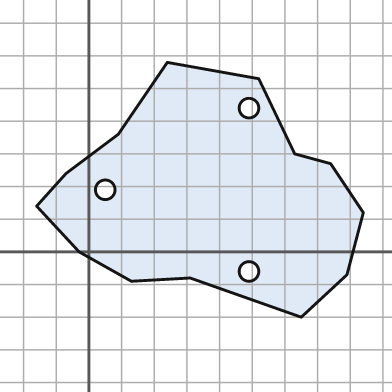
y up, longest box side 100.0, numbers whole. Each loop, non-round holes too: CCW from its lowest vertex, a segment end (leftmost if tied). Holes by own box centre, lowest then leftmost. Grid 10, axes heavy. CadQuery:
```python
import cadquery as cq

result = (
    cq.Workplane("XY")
    .moveTo(65.0, -20.0)
    .lineTo(79.0, -7.0)
    .lineTo(84.0, 12.0)
    .lineTo(74.0, 27.0)
    .lineTo(63.0, 30.0)
    .lineTo(52.0, 53.0)
    .lineTo(24.0, 58.0)
    .lineTo(9.0, 36.0)
    .lineTo(-7.0, 24.0)
    .lineTo(-16.0, 14.0)
    .lineTo(-3.0, 0.0)
    .lineTo(13.0, -9.0)
    .lineTo(31.0, -8.0)
    .close()
    .moveTo(49.0, -6.0)
    .circle(3.0)
    .moveTo(5.0, 19.0)
    .circle(3.0)
    .moveTo(49.0, 44.0)
    .circle(3.0)
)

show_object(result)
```